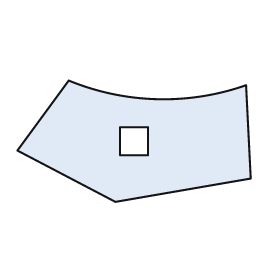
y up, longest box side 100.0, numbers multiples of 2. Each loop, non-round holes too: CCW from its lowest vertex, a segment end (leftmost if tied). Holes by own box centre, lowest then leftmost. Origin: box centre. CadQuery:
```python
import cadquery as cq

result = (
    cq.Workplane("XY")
    .moveTo(-8.0, -26.0)
    .lineTo(50.0, -16.0)
    .lineTo(48.0, 24.0)
    .threePointArc((10.0, 18.0), (-28.0, 26.0))
    .lineTo(-50.0, -4.0)
    .close()
    .moveTo(-6.0, -6.0)
    .lineTo(6.0, -6.0)
    .lineTo(6.0, 6.0)
    .lineTo(-6.0, 6.0)
    .close()
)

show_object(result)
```